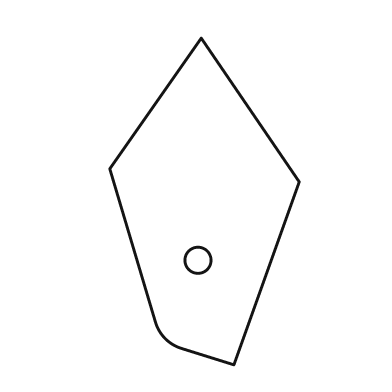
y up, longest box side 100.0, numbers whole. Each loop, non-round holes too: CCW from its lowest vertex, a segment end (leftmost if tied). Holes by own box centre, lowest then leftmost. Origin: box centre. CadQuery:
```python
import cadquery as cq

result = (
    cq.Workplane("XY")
    .moveTo(9.0, -50.0)
    .lineTo(29.0, 6.0)
    .lineTo(-1.0, 50.0)
    .lineTo(-29.0, 10.0)
    .lineTo(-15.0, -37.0)
    .threePointArc((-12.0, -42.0), (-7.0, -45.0))
    .close()
    .moveTo(-2.0, -18.0)
    .circle(4.0)
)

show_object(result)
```